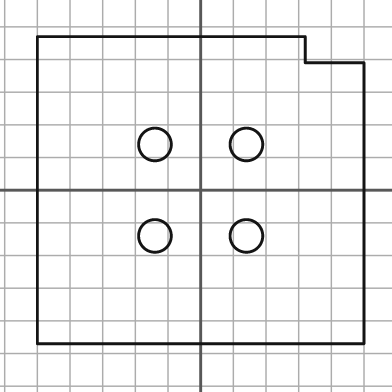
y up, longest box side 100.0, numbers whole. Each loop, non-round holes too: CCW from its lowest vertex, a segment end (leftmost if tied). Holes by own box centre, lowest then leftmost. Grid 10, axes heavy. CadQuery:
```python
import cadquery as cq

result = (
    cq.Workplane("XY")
    .moveTo(-50.0, -47.0)
    .lineTo(50.0, -47.0)
    .lineTo(50.0, 39.0)
    .lineTo(32.0, 39.0)
    .lineTo(32.0, 47.0)
    .lineTo(-50.0, 47.0)
    .close()
    .moveTo(-14.0, -14.0)
    .circle(5.0)
    .moveTo(14.0, -14.0)
    .circle(5.0)
    .moveTo(-14.0, 14.0)
    .circle(5.0)
    .moveTo(14.0, 14.0)
    .circle(5.0)
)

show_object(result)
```